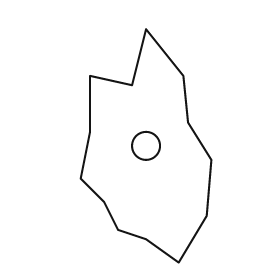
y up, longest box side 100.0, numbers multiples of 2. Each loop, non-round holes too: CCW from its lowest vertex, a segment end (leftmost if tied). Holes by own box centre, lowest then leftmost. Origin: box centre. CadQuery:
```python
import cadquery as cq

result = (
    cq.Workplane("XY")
    .moveTo(14.0, -50.0)
    .lineTo(26.0, -30.0)
    .lineTo(28.0, -6.0)
    .lineTo(18.0, 10.0)
    .lineTo(16.0, 30.0)
    .lineTo(0.0, 50.0)
    .lineTo(-6.0, 26.0)
    .lineTo(-24.0, 30.0)
    .lineTo(-24.0, 6.0)
    .lineTo(-28.0, -14.0)
    .lineTo(-18.0, -24.0)
    .lineTo(-12.0, -36.0)
    .lineTo(0.0, -40.0)
    .close()
    .moveTo(0.0, 0.0)
    .circle(6.0)
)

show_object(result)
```